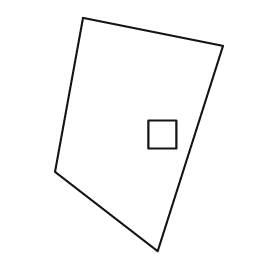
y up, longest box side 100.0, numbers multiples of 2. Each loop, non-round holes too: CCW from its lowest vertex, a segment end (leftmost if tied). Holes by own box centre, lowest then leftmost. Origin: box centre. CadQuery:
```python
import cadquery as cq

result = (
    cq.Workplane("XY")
    .moveTo(8.0, -50.0)
    .lineTo(36.0, 38.0)
    .lineTo(-24.0, 50.0)
    .lineTo(-36.0, -16.0)
    .close()
    .moveTo(4.0, -6.0)
    .lineTo(16.0, -6.0)
    .lineTo(16.0, 6.0)
    .lineTo(4.0, 6.0)
    .close()
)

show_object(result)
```